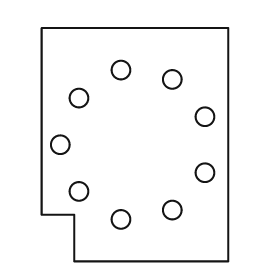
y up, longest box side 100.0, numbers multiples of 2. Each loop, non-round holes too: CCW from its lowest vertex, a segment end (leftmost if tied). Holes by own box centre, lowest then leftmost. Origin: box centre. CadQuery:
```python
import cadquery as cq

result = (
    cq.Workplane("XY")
    .moveTo(-26.0, -50.0)
    .lineTo(40.0, -50.0)
    .lineTo(40.0, 50.0)
    .lineTo(-40.0, 50.0)
    .lineTo(-40.0, -30.0)
    .lineTo(-26.0, -30.0)
    .close()
    .moveTo(-6.0, -32.0)
    .circle(4.0)
    .moveTo(16.0, -28.0)
    .circle(4.0)
    .moveTo(-24.0, -20.0)
    .circle(4.0)
    .moveTo(30.0, -12.0)
    .circle(4.0)
    .moveTo(-32.0, 0.0)
    .circle(4.0)
    .moveTo(30.0, 12.0)
    .circle(4.0)
    .moveTo(-24.0, 20.0)
    .circle(4.0)
    .moveTo(16.0, 28.0)
    .circle(4.0)
    .moveTo(-6.0, 32.0)
    .circle(4.0)
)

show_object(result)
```